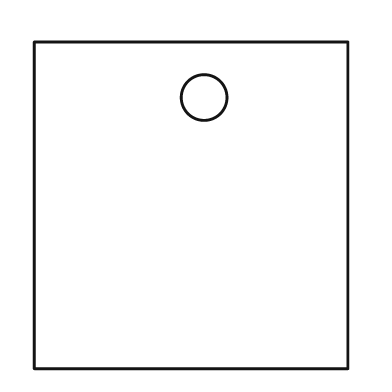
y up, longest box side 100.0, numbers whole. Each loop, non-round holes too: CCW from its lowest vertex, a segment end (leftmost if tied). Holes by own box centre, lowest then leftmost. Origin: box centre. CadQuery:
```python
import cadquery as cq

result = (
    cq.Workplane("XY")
    .moveTo(-48.0, -50.0)
    .lineTo(48.0, -50.0)
    .lineTo(48.0, 50.0)
    .lineTo(-48.0, 50.0)
    .close()
    .moveTo(4.0, 33.0)
    .circle(7.0)
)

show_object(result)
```